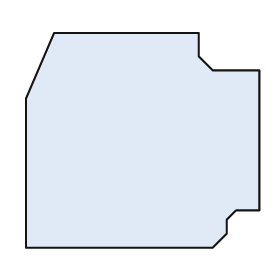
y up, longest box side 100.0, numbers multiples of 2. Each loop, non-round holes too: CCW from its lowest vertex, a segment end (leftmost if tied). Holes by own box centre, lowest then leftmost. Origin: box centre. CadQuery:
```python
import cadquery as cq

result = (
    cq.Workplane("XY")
    .moveTo(-50.0, -46.0)
    .lineTo(30.0, -46.0)
    .lineTo(36.0, -40.0)
    .lineTo(36.0, -34.0)
    .lineTo(40.0, -30.0)
    .lineTo(50.0, -30.0)
    .lineTo(50.0, 30.0)
    .lineTo(30.0, 30.0)
    .lineTo(24.0, 36.0)
    .lineTo(24.0, 46.0)
    .lineTo(-38.0, 46.0)
    .lineTo(-50.0, 18.0)
    .close()
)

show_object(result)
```